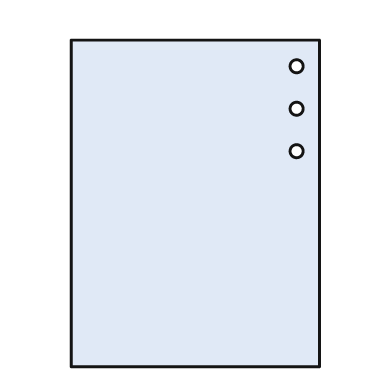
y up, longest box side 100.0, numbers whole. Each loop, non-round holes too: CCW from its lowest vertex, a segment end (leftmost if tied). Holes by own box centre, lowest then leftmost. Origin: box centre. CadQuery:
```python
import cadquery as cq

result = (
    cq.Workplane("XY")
    .moveTo(-38.0, -50.0)
    .lineTo(38.0, -50.0)
    .lineTo(38.0, 50.0)
    .lineTo(-38.0, 50.0)
    .close()
    .moveTo(31.0, 16.0)
    .circle(2.0)
    .moveTo(31.0, 29.0)
    .circle(2.0)
    .moveTo(31.0, 42.0)
    .circle(2.0)
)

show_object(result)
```